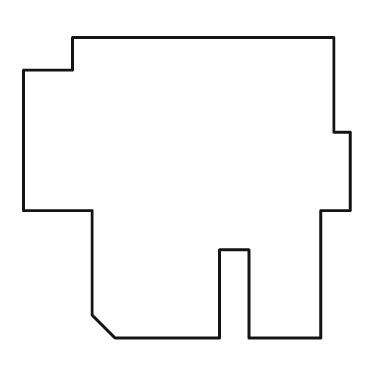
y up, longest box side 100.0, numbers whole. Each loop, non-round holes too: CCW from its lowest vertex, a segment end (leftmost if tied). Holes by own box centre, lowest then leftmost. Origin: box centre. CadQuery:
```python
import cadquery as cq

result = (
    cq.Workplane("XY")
    .moveTo(-22.0, -46.0)
    .lineTo(10.0, -46.0)
    .lineTo(10.0, -19.0)
    .lineTo(19.0, -19.0)
    .lineTo(19.0, -46.0)
    .lineTo(41.0, -46.0)
    .lineTo(41.0, -7.0)
    .lineTo(50.0, -7.0)
    .lineTo(50.0, 17.0)
    .lineTo(45.0, 17.0)
    .lineTo(45.0, 46.0)
    .lineTo(-35.0, 46.0)
    .lineTo(-35.0, 36.0)
    .lineTo(-50.0, 36.0)
    .lineTo(-50.0, -7.0)
    .lineTo(-29.0, -7.0)
    .lineTo(-29.0, -39.0)
    .close()
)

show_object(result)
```